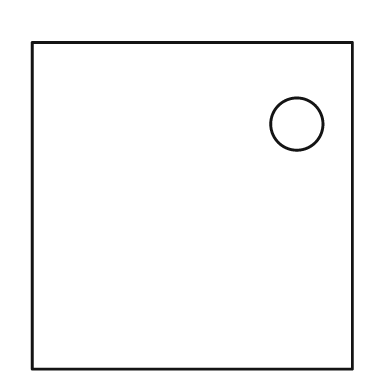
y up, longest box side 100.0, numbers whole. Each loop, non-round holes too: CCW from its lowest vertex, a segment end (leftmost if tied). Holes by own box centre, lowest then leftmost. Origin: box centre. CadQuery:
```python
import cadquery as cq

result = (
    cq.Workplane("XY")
    .moveTo(-49.0, -50.0)
    .lineTo(49.0, -50.0)
    .lineTo(49.0, 50.0)
    .lineTo(-49.0, 50.0)
    .close()
    .moveTo(32.0, 25.0)
    .circle(8.0)
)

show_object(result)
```